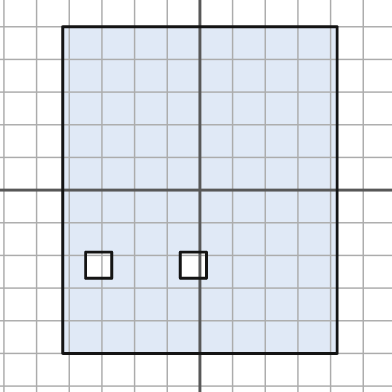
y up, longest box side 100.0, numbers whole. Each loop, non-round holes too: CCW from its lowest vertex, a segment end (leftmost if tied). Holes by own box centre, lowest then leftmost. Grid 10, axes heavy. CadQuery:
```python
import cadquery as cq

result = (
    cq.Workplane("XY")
    .moveTo(-42.0, -50.0)
    .lineTo(42.0, -50.0)
    .lineTo(42.0, 50.0)
    .lineTo(-42.0, 50.0)
    .close()
    .moveTo(-35.0, -27.0)
    .lineTo(-27.0, -27.0)
    .lineTo(-27.0, -19.0)
    .lineTo(-35.0, -19.0)
    .close()
    .moveTo(-6.0, -27.0)
    .lineTo(2.0, -27.0)
    .lineTo(2.0, -19.0)
    .lineTo(-6.0, -19.0)
    .close()
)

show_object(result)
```